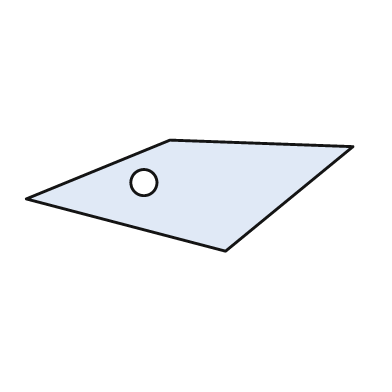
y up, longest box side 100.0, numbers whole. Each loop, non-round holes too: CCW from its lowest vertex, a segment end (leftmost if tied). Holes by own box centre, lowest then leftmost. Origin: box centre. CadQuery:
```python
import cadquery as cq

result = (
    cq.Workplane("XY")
    .moveTo(11.0, -17.0)
    .lineTo(50.0, 15.0)
    .lineTo(-6.0, 17.0)
    .lineTo(-50.0, -1.0)
    .close()
    .moveTo(-14.0, 4.0)
    .circle(4.0)
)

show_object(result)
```